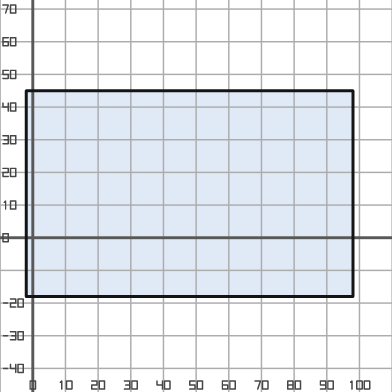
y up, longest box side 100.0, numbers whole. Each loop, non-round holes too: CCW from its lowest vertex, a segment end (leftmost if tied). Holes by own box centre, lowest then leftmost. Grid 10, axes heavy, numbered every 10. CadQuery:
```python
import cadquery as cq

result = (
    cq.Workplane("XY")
    .moveTo(-2.0, -18.0)
    .lineTo(98.0, -18.0)
    .lineTo(98.0, 45.0)
    .lineTo(-2.0, 45.0)
    .close()
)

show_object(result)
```